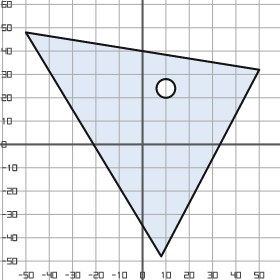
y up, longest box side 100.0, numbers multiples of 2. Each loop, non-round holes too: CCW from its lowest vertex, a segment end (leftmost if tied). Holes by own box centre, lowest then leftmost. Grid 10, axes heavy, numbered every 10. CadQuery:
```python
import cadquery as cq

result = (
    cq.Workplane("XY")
    .moveTo(8.0, -48.0)
    .lineTo(50.0, 32.0)
    .lineTo(-50.0, 48.0)
    .close()
    .moveTo(10.0, 24.0)
    .circle(4.0)
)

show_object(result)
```